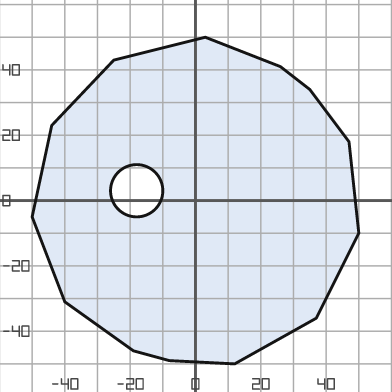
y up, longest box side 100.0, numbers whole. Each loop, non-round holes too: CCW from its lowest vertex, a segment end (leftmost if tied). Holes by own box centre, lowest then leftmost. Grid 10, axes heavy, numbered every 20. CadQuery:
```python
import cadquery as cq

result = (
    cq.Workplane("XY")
    .moveTo(12.0, -50.0)
    .lineTo(37.0, -36.0)
    .lineTo(50.0, -10.0)
    .lineTo(47.0, 18.0)
    .lineTo(35.0, 34.0)
    .lineTo(26.0, 41.0)
    .lineTo(3.0, 50.0)
    .lineTo(-25.0, 43.0)
    .lineTo(-44.0, 23.0)
    .lineTo(-50.0, -5.0)
    .lineTo(-40.0, -31.0)
    .lineTo(-19.0, -46.0)
    .lineTo(-8.0, -49.0)
    .close()
    .moveTo(-18.0, 3.0)
    .circle(8.0)
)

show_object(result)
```